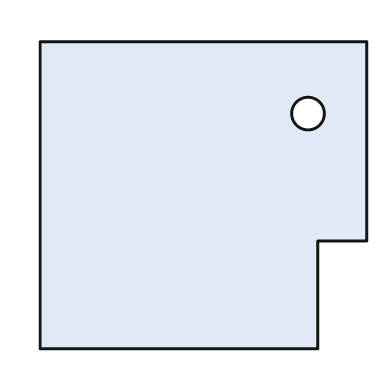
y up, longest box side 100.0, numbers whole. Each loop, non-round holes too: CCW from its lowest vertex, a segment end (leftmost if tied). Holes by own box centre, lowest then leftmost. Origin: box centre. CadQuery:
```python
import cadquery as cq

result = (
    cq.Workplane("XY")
    .moveTo(-50.0, -47.0)
    .lineTo(35.0, -47.0)
    .lineTo(35.0, -14.0)
    .lineTo(50.0, -14.0)
    .lineTo(50.0, 47.0)
    .lineTo(-50.0, 47.0)
    .close()
    .moveTo(32.0, 25.0)
    .circle(5.0)
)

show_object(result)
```